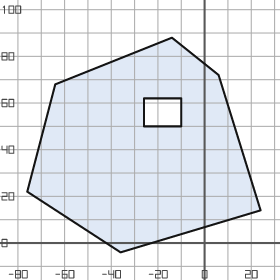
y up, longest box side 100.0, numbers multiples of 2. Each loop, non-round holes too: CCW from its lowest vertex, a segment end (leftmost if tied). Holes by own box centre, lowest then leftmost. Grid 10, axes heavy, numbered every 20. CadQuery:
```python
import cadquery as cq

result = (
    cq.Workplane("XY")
    .moveTo(-36.0, -4.0)
    .lineTo(24.0, 14.0)
    .lineTo(6.0, 72.0)
    .lineTo(-14.0, 88.0)
    .lineTo(-64.0, 68.0)
    .lineTo(-76.0, 22.0)
    .close()
    .moveTo(-26.0, 50.0)
    .lineTo(-10.0, 50.0)
    .lineTo(-10.0, 62.0)
    .lineTo(-26.0, 62.0)
    .close()
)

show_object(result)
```